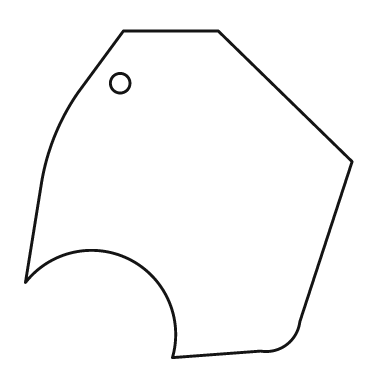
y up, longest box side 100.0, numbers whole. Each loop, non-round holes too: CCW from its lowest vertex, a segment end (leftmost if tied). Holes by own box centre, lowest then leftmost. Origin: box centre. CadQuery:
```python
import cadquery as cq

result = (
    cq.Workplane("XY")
    .moveTo(-5.0, -50.0)
    .lineTo(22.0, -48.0)
    .threePointArc((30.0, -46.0), (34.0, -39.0))
    .lineTo(50.0, 10.0)
    .lineTo(9.0, 50.0)
    .lineTo(-20.0, 50.0)
    .lineTo(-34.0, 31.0)
    .threePointArc((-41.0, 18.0), (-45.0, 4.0))
    .lineTo(-50.0, -27.0)
    .threePointArc((-18.0, -20.0), (-5.0, -50.0))
    .close()
    .moveTo(-21.0, 34.0)
    .circle(3.0)
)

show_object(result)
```